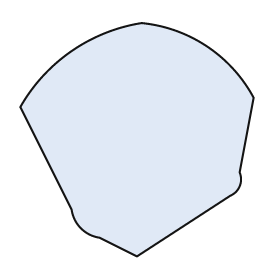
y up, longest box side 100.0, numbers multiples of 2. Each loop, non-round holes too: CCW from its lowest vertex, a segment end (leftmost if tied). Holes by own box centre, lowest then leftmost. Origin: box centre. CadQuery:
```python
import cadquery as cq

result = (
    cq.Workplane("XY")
    .moveTo(0.0, -50.0)
    .lineTo(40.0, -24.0)
    .threePointArc((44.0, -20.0), (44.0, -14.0))
    .lineTo(50.0, 18.0)
    .threePointArc((30.0, 40.0), (2.0, 50.0))
    .threePointArc((-28.0, 38.0), (-50.0, 14.0))
    .lineTo(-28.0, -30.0)
    .threePointArc((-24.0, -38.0), (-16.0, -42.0))
    .close()
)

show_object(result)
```